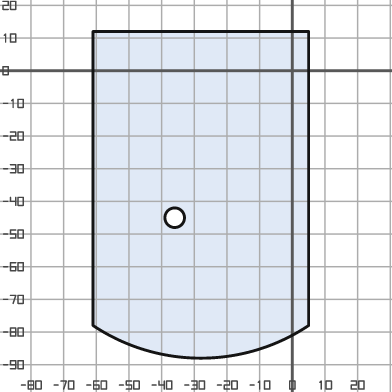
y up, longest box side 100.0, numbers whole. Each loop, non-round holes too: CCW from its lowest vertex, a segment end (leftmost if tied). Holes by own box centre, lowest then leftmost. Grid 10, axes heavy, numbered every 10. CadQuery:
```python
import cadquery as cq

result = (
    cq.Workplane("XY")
    .moveTo(-61.0, -78.0)
    .threePointArc((-28.0, -88.0), (5.0, -78.0))
    .lineTo(5.0, 12.0)
    .lineTo(-61.0, 12.0)
    .close()
    .moveTo(-36.0, -45.0)
    .circle(3.0)
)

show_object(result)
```